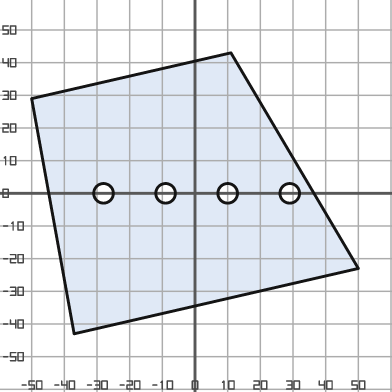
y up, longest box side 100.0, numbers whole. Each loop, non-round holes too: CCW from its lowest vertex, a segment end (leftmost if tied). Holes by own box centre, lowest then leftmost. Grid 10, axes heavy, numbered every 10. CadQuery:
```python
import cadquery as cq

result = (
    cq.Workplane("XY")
    .moveTo(-37.0, -43.0)
    .lineTo(50.0, -23.0)
    .lineTo(11.0, 43.0)
    .lineTo(-50.0, 29.0)
    .close()
    .moveTo(-28.0, 0.0)
    .circle(3.0)
    .moveTo(-9.0, 0.0)
    .circle(3.0)
    .moveTo(10.0, 0.0)
    .circle(3.0)
    .moveTo(29.0, 0.0)
    .circle(3.0)
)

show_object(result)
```